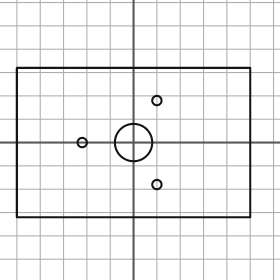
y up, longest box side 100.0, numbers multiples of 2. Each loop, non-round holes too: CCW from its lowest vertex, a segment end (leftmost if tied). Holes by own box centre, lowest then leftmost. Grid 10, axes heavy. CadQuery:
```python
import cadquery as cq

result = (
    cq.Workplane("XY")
    .moveTo(-50.0, -32.0)
    .lineTo(50.0, -32.0)
    .lineTo(50.0, 32.0)
    .lineTo(-50.0, 32.0)
    .close()
    .moveTo(10.0, -18.0)
    .circle(2.0)
    .moveTo(-22.0, 0.0)
    .circle(2.0)
    .moveTo(0.0, 0.0)
    .circle(8.0)
    .moveTo(10.0, 18.0)
    .circle(2.0)
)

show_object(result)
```